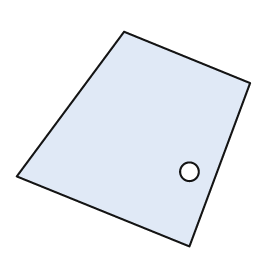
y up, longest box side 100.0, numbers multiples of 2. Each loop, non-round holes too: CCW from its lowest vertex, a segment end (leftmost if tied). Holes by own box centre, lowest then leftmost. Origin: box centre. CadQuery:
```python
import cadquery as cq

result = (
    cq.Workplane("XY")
    .moveTo(24.0, -46.0)
    .lineTo(50.0, 24.0)
    .lineTo(-4.0, 46.0)
    .lineTo(-50.0, -16.0)
    .close()
    .moveTo(24.0, -14.0)
    .circle(4.0)
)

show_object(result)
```